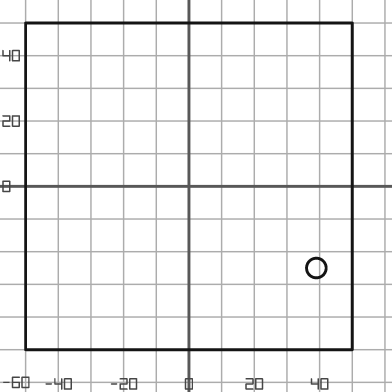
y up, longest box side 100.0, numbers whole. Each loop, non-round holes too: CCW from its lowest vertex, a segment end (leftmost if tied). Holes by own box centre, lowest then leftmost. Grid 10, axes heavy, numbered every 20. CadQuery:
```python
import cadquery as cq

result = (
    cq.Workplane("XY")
    .moveTo(-50.0, -50.0)
    .lineTo(50.0, -50.0)
    .lineTo(50.0, 50.0)
    .lineTo(-50.0, 50.0)
    .close()
    .moveTo(39.0, -25.0)
    .circle(3.0)
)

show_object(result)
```